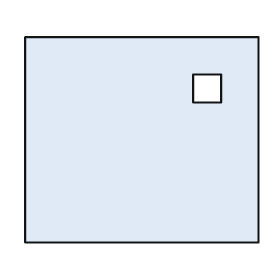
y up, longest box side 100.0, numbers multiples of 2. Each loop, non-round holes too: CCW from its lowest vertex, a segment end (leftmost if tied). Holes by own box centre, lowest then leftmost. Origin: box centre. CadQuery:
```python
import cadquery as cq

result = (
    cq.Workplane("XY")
    .moveTo(-50.0, -44.0)
    .lineTo(50.0, -44.0)
    .lineTo(50.0, 44.0)
    .lineTo(-50.0, 44.0)
    .close()
    .moveTo(22.0, 16.0)
    .lineTo(34.0, 16.0)
    .lineTo(34.0, 28.0)
    .lineTo(22.0, 28.0)
    .close()
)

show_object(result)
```